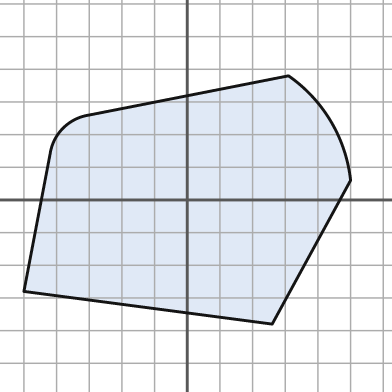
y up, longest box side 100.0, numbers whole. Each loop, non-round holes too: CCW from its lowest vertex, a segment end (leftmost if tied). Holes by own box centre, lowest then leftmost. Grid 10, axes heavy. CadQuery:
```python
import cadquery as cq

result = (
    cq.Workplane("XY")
    .moveTo(26.0, -38.0)
    .lineTo(50.0, 6.0)
    .threePointArc((44.0, 24.0), (31.0, 38.0))
    .lineTo(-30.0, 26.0)
    .threePointArc((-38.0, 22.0), (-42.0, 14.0))
    .lineTo(-50.0, -28.0)
    .close()
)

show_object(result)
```